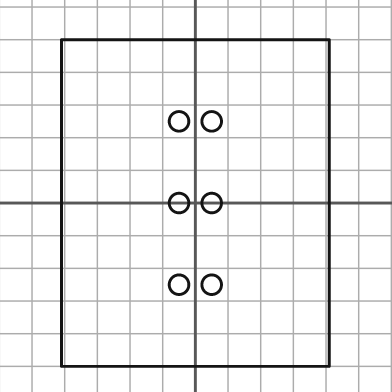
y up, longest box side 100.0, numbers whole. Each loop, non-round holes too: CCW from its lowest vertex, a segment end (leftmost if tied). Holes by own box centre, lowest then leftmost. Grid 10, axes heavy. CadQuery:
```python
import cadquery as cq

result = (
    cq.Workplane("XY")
    .moveTo(-41.0, -50.0)
    .lineTo(41.0, -50.0)
    .lineTo(41.0, 50.0)
    .lineTo(-41.0, 50.0)
    .close()
    .moveTo(-5.0, -25.0)
    .circle(3.0)
    .moveTo(5.0, -25.0)
    .circle(3.0)
    .moveTo(-5.0, 0.0)
    .circle(3.0)
    .moveTo(5.0, 0.0)
    .circle(3.0)
    .moveTo(-5.0, 25.0)
    .circle(3.0)
    .moveTo(5.0, 25.0)
    .circle(3.0)
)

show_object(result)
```